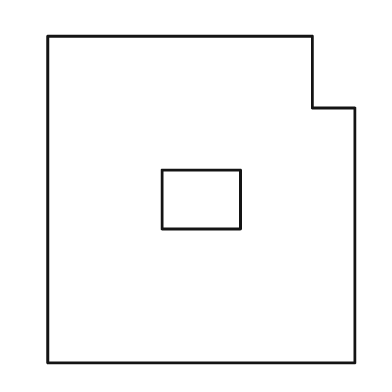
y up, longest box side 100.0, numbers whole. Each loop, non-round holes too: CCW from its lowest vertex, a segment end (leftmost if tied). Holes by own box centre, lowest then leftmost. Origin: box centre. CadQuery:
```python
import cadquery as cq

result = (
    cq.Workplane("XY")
    .moveTo(-47.0, -50.0)
    .lineTo(47.0, -50.0)
    .lineTo(47.0, 28.0)
    .lineTo(34.0, 28.0)
    .lineTo(34.0, 50.0)
    .lineTo(-47.0, 50.0)
    .close()
    .moveTo(-12.0, -9.0)
    .lineTo(12.0, -9.0)
    .lineTo(12.0, 9.0)
    .lineTo(-12.0, 9.0)
    .close()
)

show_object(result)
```